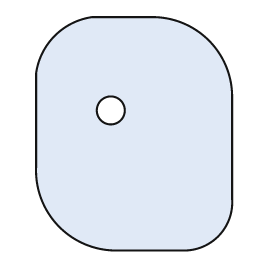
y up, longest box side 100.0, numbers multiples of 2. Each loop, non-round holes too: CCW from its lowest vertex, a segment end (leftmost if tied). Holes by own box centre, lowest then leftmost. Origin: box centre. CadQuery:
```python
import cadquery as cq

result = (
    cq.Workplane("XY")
    .moveTo(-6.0, -50.0)
    .lineTo(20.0, -50.0)
    .threePointArc((36.0, -44.0), (42.0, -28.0))
    .lineTo(42.0, 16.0)
    .threePointArc((32.0, 40.0), (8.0, 50.0))
    .lineTo(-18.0, 50.0)
    .threePointArc((-34.0, 42.0), (-42.0, 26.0))
    .lineTo(-42.0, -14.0)
    .threePointArc((-32.0, -40.0), (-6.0, -50.0))
    .close()
    .moveTo(-10.0, 10.0)
    .circle(6.0)
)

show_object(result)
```